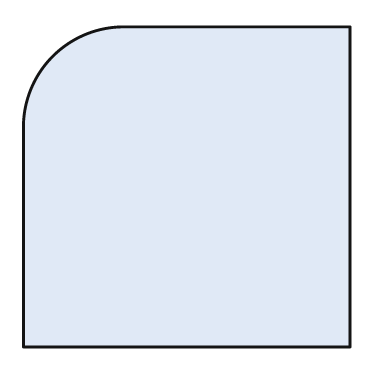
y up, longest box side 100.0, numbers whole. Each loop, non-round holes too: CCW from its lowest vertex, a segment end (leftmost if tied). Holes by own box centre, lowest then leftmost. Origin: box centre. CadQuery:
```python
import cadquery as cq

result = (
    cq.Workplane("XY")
    .moveTo(-50.0, -49.0)
    .lineTo(50.0, -49.0)
    .lineTo(50.0, 49.0)
    .lineTo(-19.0, 49.0)
    .threePointArc((-41.0, 40.0), (-50.0, 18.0))
    .close()
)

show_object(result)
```